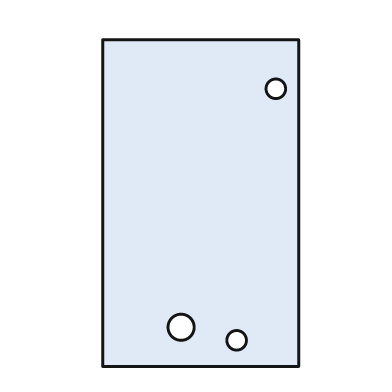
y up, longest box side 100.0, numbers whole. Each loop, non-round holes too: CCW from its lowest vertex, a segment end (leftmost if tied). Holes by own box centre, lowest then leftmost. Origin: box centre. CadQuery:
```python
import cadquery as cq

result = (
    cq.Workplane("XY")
    .moveTo(-30.0, -50.0)
    .lineTo(30.0, -50.0)
    .lineTo(30.0, 50.0)
    .lineTo(-30.0, 50.0)
    .close()
    .moveTo(11.0, -42.0)
    .circle(3.0)
    .moveTo(-6.0, -38.0)
    .circle(4.0)
    .moveTo(23.0, 35.0)
    .circle(3.0)
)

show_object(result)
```